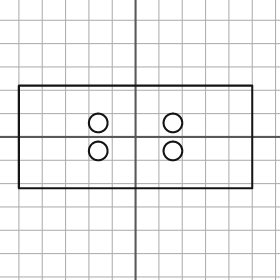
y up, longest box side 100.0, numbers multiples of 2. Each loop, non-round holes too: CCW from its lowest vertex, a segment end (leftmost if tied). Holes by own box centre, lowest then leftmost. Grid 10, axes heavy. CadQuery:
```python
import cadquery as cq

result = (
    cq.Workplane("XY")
    .moveTo(-50.0, -22.0)
    .lineTo(50.0, -22.0)
    .lineTo(50.0, 22.0)
    .lineTo(-50.0, 22.0)
    .close()
    .moveTo(-16.0, -6.0)
    .circle(4.0)
    .moveTo(16.0, -6.0)
    .circle(4.0)
    .moveTo(-16.0, 6.0)
    .circle(4.0)
    .moveTo(16.0, 6.0)
    .circle(4.0)
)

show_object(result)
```